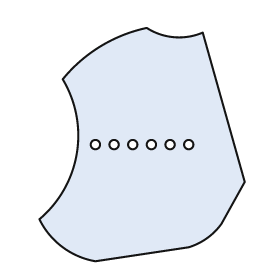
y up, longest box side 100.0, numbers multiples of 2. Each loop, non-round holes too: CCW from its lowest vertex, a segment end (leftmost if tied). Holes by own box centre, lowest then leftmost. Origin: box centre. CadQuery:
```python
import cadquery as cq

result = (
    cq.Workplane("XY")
    .moveTo(-20.0, -50.0)
    .lineTo(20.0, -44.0)
    .threePointArc((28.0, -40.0), (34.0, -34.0))
    .lineTo(44.0, -16.0)
    .lineTo(26.0, 48.0)
    .threePointArc((14.0, 46.0), (2.0, 50.0))
    .threePointArc((-18.0, 42.0), (-34.0, 28.0))
    .threePointArc((-28.0, -4.0), (-44.0, -32.0))
    .threePointArc((-34.0, -44.0), (-20.0, -50.0))
    .close()
    .moveTo(-20.0, 0.0)
    .circle(2.0)
    .moveTo(-12.0, 0.0)
    .circle(2.0)
    .moveTo(-4.0, 0.0)
    .circle(2.0)
    .moveTo(4.0, 0.0)
    .circle(2.0)
    .moveTo(12.0, 0.0)
    .circle(2.0)
    .moveTo(20.0, 0.0)
    .circle(2.0)
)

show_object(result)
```